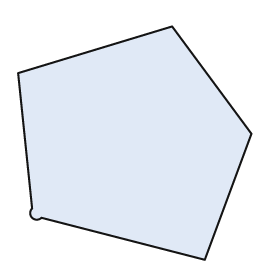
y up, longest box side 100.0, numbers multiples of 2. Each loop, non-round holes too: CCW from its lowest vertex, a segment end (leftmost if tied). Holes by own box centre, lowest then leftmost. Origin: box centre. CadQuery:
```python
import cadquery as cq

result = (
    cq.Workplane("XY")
    .moveTo(30.0, -50.0)
    .lineTo(50.0, 4.0)
    .lineTo(16.0, 50.0)
    .lineTo(-50.0, 30.0)
    .lineTo(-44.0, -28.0)
    .threePointArc((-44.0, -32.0), (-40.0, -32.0))
    .close()
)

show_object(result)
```